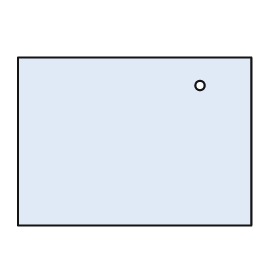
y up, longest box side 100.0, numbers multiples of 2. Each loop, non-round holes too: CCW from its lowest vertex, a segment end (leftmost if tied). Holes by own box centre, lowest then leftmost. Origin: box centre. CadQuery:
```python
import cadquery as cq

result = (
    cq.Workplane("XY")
    .moveTo(-50.0, -36.0)
    .lineTo(50.0, -36.0)
    .lineTo(50.0, 36.0)
    .lineTo(-50.0, 36.0)
    .close()
    .moveTo(28.0, 24.0)
    .circle(2.0)
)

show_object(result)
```